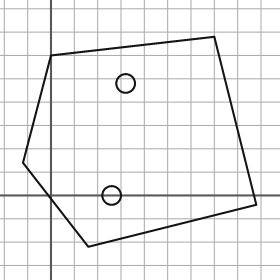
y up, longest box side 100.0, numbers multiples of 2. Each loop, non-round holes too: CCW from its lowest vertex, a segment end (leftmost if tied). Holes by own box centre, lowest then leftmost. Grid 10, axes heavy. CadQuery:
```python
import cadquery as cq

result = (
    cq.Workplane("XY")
    .moveTo(16.0, -22.0)
    .lineTo(88.0, -4.0)
    .lineTo(70.0, 68.0)
    .lineTo(0.0, 60.0)
    .lineTo(-12.0, 14.0)
    .close()
    .moveTo(26.0, 0.0)
    .circle(4.0)
    .moveTo(32.0, 48.0)
    .circle(4.0)
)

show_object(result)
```